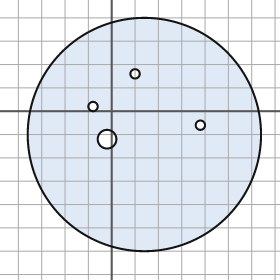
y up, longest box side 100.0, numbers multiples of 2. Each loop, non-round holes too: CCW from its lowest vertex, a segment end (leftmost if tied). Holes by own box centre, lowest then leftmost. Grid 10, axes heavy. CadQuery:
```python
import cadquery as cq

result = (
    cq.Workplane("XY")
    .moveTo(14.0, -10.0)
    .circle(50.0)
    .moveTo(-2.0, -12.0)
    .circle(4.0)
    .moveTo(38.0, -6.0)
    .circle(2.0)
    .moveTo(-8.0, 2.0)
    .circle(2.0)
    .moveTo(10.0, 16.0)
    .circle(2.0)
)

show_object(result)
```